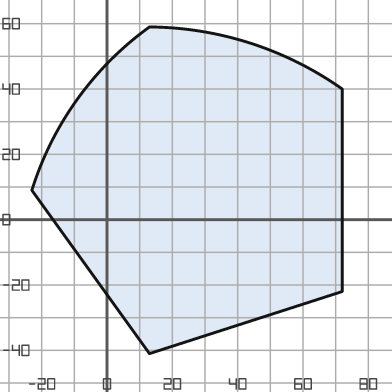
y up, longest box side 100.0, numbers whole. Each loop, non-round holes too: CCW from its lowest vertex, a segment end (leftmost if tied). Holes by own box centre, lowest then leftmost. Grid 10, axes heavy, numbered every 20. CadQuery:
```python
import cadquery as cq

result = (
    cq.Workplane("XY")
    .moveTo(13.0, -41.0)
    .lineTo(72.0, -22.0)
    .lineTo(72.0, 40.0)
    .threePointArc((44.0, 54.0), (13.0, 59.0))
    .threePointArc((-9.0, 37.0), (-23.0, 9.0))
    .close()
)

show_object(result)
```